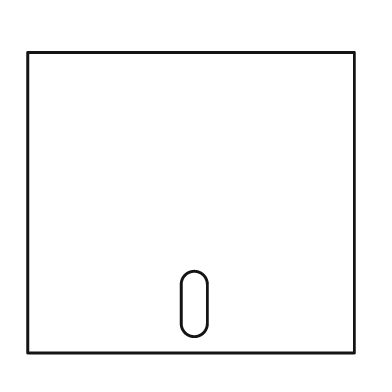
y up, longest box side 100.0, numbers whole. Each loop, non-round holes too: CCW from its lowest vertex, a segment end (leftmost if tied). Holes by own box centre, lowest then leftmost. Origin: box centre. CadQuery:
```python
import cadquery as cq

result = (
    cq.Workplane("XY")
    .moveTo(-50.0, -46.0)
    .lineTo(50.0, -46.0)
    .lineTo(50.0, 46.0)
    .lineTo(-50.0, 46.0)
    .close()
    .moveTo(-3.0, -37.0)
    .threePointArc((1.0, -41.0), (5.0, -37.0))
    .lineTo(5.0, -25.0)
    .threePointArc((1.0, -21.0), (-3.0, -25.0))
    .close()
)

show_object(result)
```